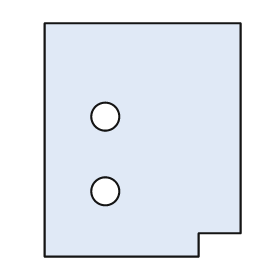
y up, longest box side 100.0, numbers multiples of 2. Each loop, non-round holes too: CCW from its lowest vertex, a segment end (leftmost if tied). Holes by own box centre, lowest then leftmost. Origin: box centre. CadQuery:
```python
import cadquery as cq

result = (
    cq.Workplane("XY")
    .moveTo(-42.0, -50.0)
    .lineTo(24.0, -50.0)
    .lineTo(24.0, -40.0)
    .lineTo(42.0, -40.0)
    .lineTo(42.0, 50.0)
    .lineTo(-42.0, 50.0)
    .close()
    .moveTo(-16.0, -22.0)
    .circle(6.0)
    .moveTo(-16.0, 10.0)
    .circle(6.0)
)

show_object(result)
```